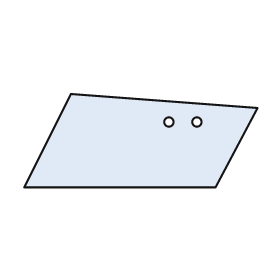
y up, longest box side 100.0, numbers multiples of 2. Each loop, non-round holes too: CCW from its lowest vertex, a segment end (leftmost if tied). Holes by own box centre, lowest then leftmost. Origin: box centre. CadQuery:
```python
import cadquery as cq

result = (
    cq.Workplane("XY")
    .moveTo(-50.0, -20.0)
    .lineTo(32.0, -20.0)
    .lineTo(50.0, 14.0)
    .lineTo(-30.0, 20.0)
    .close()
    .moveTo(12.0, 8.0)
    .circle(2.0)
    .moveTo(24.0, 8.0)
    .circle(2.0)
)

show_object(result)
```